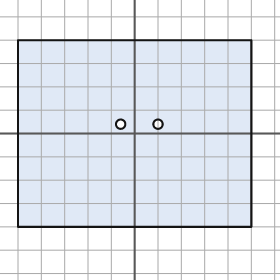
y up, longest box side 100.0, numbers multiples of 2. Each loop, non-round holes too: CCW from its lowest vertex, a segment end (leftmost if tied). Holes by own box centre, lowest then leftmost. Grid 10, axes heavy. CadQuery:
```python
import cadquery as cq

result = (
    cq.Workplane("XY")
    .moveTo(-50.0, -40.0)
    .lineTo(50.0, -40.0)
    .lineTo(50.0, 40.0)
    .lineTo(-50.0, 40.0)
    .close()
    .moveTo(-6.0, 4.0)
    .circle(2.0)
    .moveTo(10.0, 4.0)
    .circle(2.0)
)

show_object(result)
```